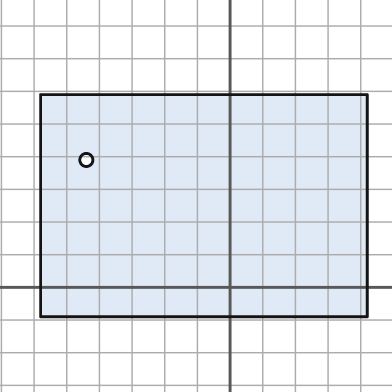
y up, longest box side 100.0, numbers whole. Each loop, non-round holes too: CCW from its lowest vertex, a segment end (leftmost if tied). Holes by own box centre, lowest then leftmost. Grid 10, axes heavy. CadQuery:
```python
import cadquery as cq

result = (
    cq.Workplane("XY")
    .moveTo(-58.0, -9.0)
    .lineTo(42.0, -9.0)
    .lineTo(42.0, 59.0)
    .lineTo(-58.0, 59.0)
    .close()
    .moveTo(-44.0, 39.0)
    .circle(2.0)
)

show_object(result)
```